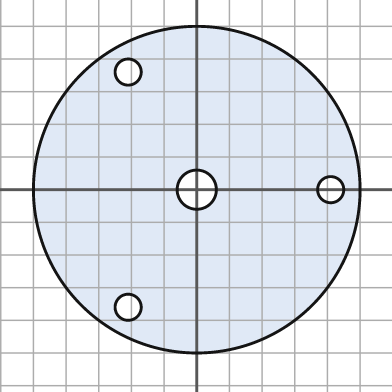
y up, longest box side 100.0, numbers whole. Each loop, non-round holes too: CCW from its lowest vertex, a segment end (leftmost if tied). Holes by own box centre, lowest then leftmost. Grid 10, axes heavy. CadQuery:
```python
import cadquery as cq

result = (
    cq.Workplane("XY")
    .moveTo(0.0, 0.0)
    .circle(50.0)
    .moveTo(-21.0, -36.0)
    .circle(4.0)
    .moveTo(0.0, 0.0)
    .circle(6.0)
    .moveTo(41.0, 0.0)
    .circle(4.0)
    .moveTo(-21.0, 36.0)
    .circle(4.0)
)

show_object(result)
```